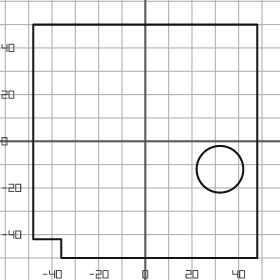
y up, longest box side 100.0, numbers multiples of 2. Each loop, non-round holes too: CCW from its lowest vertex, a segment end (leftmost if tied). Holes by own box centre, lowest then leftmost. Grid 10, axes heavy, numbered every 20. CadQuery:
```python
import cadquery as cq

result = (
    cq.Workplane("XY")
    .moveTo(-36.0, -50.0)
    .lineTo(48.0, -50.0)
    .lineTo(48.0, 50.0)
    .lineTo(-48.0, 50.0)
    .lineTo(-48.0, -42.0)
    .lineTo(-36.0, -42.0)
    .close()
    .moveTo(32.0, -12.0)
    .circle(10.0)
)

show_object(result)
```